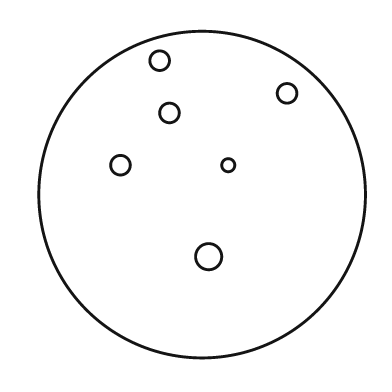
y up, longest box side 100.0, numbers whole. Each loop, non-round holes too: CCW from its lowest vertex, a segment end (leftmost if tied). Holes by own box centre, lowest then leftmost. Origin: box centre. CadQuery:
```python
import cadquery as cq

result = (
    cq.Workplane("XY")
    .moveTo(0.0, 0.0)
    .circle(50.0)
    .moveTo(2.0, -19.0)
    .circle(4.0)
    .moveTo(-25.0, 9.0)
    .circle(3.0)
    .moveTo(8.0, 9.0)
    .circle(2.0)
    .moveTo(-10.0, 25.0)
    .circle(3.0)
    .moveTo(26.0, 31.0)
    .circle(3.0)
    .moveTo(-13.0, 41.0)
    .circle(3.0)
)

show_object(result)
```